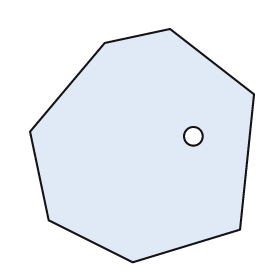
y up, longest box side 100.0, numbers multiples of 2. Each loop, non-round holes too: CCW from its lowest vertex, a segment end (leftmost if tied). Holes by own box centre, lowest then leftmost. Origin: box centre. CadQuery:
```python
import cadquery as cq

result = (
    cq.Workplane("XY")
    .moveTo(-4.0, -50.0)
    .lineTo(42.0, -36.0)
    .lineTo(48.0, 22.0)
    .lineTo(12.0, 50.0)
    .lineTo(-16.0, 44.0)
    .lineTo(-48.0, 6.0)
    .lineTo(-40.0, -32.0)
    .close()
    .moveTo(22.0, 4.0)
    .circle(4.0)
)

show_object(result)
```